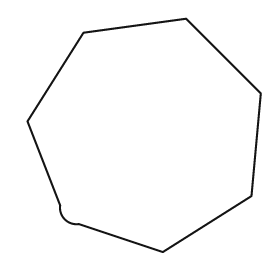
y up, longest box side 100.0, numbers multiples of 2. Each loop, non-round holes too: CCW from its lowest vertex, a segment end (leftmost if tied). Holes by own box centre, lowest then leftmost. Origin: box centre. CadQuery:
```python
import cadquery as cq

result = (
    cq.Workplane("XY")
    .moveTo(8.0, -50.0)
    .lineTo(46.0, -26.0)
    .lineTo(50.0, 18.0)
    .lineTo(18.0, 50.0)
    .lineTo(-26.0, 44.0)
    .lineTo(-50.0, 6.0)
    .lineTo(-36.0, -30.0)
    .threePointArc((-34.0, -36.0), (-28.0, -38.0))
    .close()
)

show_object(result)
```